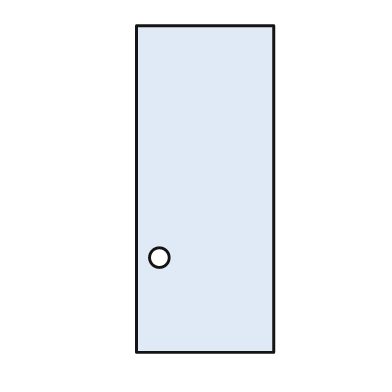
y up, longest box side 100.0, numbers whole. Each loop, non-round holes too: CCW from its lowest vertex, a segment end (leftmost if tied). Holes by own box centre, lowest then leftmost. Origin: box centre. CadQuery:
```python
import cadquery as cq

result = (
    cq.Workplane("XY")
    .moveTo(-21.0, -50.0)
    .lineTo(21.0, -50.0)
    .lineTo(21.0, 50.0)
    .lineTo(-21.0, 50.0)
    .close()
    .moveTo(-14.0, -21.0)
    .circle(3.0)
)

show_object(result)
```